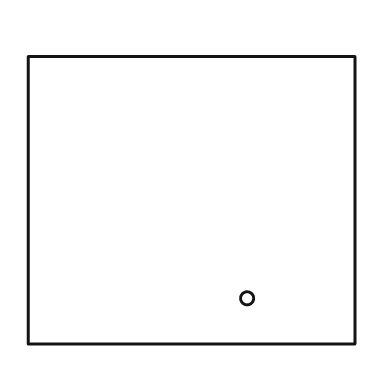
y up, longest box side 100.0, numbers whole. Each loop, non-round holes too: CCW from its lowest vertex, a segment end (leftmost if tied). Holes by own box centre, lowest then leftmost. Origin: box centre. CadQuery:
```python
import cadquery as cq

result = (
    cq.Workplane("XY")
    .moveTo(-50.0, -44.0)
    .lineTo(50.0, -44.0)
    .lineTo(50.0, 44.0)
    .lineTo(-50.0, 44.0)
    .close()
    .moveTo(17.0, -30.0)
    .circle(2.0)
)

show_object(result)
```